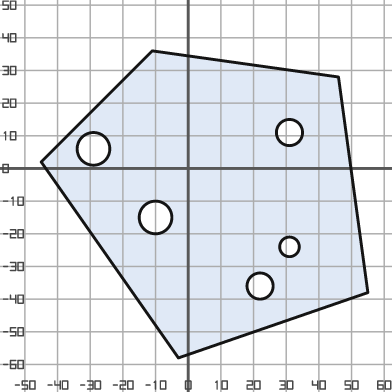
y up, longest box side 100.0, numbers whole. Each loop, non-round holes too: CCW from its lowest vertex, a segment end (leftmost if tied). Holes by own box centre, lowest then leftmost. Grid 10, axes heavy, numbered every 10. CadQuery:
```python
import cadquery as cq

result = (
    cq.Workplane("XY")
    .moveTo(-3.0, -58.0)
    .lineTo(55.0, -38.0)
    .lineTo(46.0, 28.0)
    .lineTo(-11.0, 36.0)
    .lineTo(-45.0, 2.0)
    .close()
    .moveTo(22.0, -36.0)
    .circle(4.0)
    .moveTo(31.0, -24.0)
    .circle(3.0)
    .moveTo(-10.0, -15.0)
    .circle(5.0)
    .moveTo(-29.0, 6.0)
    .circle(5.0)
    .moveTo(31.0, 11.0)
    .circle(4.0)
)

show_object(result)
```